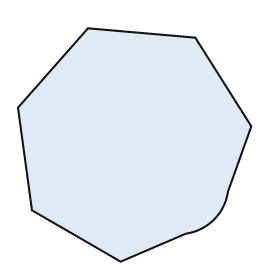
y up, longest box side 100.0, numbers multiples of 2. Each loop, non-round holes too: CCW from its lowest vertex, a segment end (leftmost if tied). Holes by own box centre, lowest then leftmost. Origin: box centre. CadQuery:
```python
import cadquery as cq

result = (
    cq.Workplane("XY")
    .moveTo(-6.0, -50.0)
    .lineTo(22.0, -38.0)
    .threePointArc((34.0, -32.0), (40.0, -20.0))
    .lineTo(50.0, 8.0)
    .lineTo(26.0, 46.0)
    .lineTo(-20.0, 50.0)
    .lineTo(-50.0, 16.0)
    .lineTo(-44.0, -28.0)
    .close()
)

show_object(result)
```